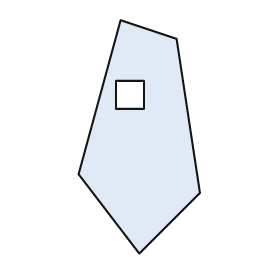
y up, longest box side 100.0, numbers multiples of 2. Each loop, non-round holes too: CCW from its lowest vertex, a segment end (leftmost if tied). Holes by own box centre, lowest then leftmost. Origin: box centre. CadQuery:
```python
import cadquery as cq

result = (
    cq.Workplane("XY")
    .moveTo(0.0, -50.0)
    .lineTo(26.0, -24.0)
    .lineTo(16.0, 42.0)
    .lineTo(-8.0, 50.0)
    .lineTo(-26.0, -16.0)
    .close()
    .moveTo(-10.0, 12.0)
    .lineTo(2.0, 12.0)
    .lineTo(2.0, 24.0)
    .lineTo(-10.0, 24.0)
    .close()
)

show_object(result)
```